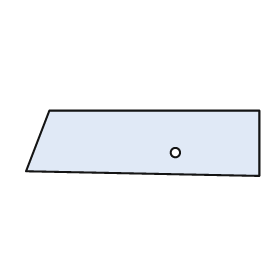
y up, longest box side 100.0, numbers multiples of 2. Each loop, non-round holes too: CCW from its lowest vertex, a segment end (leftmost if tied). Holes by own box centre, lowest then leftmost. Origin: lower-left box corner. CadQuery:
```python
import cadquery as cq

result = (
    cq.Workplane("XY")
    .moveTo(100.0, 0.0)
    .lineTo(100.0, 28.0)
    .lineTo(10.0, 28.0)
    .lineTo(0.0, 2.0)
    .close()
    .moveTo(64.0, 10.0)
    .circle(2.0)
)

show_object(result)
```